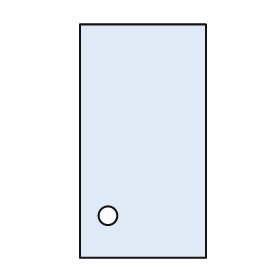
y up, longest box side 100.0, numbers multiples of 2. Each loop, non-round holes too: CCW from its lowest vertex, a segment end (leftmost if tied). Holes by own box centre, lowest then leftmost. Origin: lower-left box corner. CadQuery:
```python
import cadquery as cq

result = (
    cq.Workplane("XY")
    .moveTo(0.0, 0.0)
    .lineTo(54.0, 0.0)
    .lineTo(54.0, 100.0)
    .lineTo(0.0, 100.0)
    .close()
    .moveTo(12.0, 18.0)
    .circle(4.0)
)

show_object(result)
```